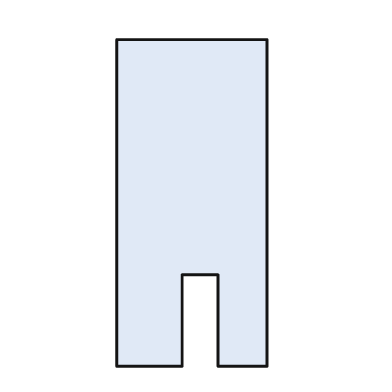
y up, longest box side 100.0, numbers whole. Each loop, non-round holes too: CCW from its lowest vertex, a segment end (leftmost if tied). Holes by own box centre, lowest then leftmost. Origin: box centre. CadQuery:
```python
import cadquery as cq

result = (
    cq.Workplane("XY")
    .moveTo(-23.0, -50.0)
    .lineTo(-3.0, -50.0)
    .lineTo(-3.0, -22.0)
    .lineTo(8.0, -22.0)
    .lineTo(8.0, -50.0)
    .lineTo(23.0, -50.0)
    .lineTo(23.0, 50.0)
    .lineTo(-23.0, 50.0)
    .close()
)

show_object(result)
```